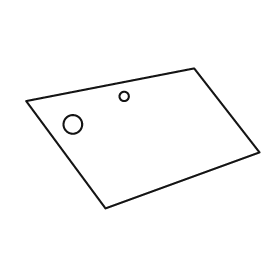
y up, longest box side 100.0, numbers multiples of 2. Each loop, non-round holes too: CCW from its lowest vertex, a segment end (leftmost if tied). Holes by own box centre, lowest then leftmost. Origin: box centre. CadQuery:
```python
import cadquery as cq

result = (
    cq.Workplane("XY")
    .moveTo(-16.0, -30.0)
    .lineTo(50.0, -6.0)
    .lineTo(22.0, 30.0)
    .lineTo(-50.0, 16.0)
    .close()
    .moveTo(-30.0, 6.0)
    .circle(4.0)
    .moveTo(-8.0, 18.0)
    .circle(2.0)
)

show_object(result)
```